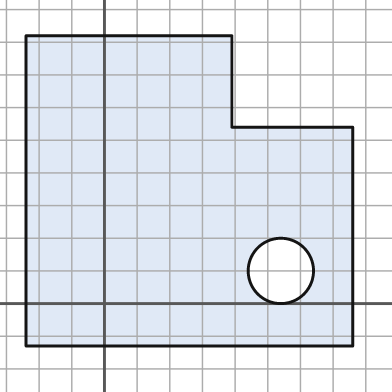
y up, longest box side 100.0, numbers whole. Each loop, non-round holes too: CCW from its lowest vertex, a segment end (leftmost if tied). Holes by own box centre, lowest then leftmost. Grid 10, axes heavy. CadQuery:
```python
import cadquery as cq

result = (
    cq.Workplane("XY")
    .moveTo(-24.0, -13.0)
    .lineTo(76.0, -13.0)
    .lineTo(76.0, 54.0)
    .lineTo(39.0, 54.0)
    .lineTo(39.0, 82.0)
    .lineTo(-24.0, 82.0)
    .close()
    .moveTo(54.0, 10.0)
    .circle(10.0)
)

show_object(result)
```